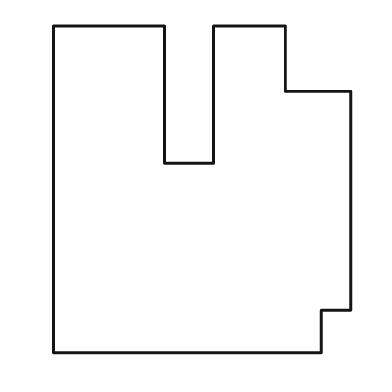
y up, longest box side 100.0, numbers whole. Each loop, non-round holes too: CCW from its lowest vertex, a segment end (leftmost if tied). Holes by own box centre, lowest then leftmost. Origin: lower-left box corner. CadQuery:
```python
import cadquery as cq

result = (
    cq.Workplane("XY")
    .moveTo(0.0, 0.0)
    .lineTo(82.0, 0.0)
    .lineTo(82.0, 13.0)
    .lineTo(91.0, 13.0)
    .lineTo(91.0, 80.0)
    .lineTo(71.0, 80.0)
    .lineTo(71.0, 100.0)
    .lineTo(49.0, 100.0)
    .lineTo(49.0, 58.0)
    .lineTo(34.0, 58.0)
    .lineTo(34.0, 100.0)
    .lineTo(0.0, 100.0)
    .close()
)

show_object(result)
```